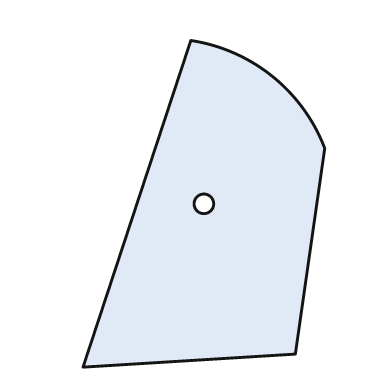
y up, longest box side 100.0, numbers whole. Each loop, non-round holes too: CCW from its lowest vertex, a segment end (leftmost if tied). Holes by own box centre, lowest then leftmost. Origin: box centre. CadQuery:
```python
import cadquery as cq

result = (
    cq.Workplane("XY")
    .moveTo(-37.0, -50.0)
    .lineTo(28.0, -46.0)
    .lineTo(37.0, 17.0)
    .threePointArc((21.0, 39.0), (-4.0, 50.0))
    .close()
    .moveTo(0.0, 0.0)
    .circle(3.0)
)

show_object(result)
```